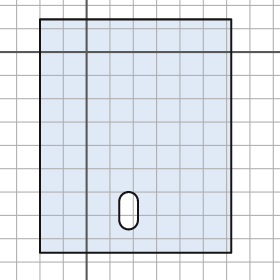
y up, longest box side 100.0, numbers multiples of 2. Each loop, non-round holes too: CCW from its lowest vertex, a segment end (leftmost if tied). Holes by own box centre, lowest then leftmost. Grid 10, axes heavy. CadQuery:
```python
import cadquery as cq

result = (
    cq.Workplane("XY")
    .moveTo(-20.0, -86.0)
    .lineTo(62.0, -86.0)
    .lineTo(62.0, 14.0)
    .lineTo(-20.0, 14.0)
    .close()
    .moveTo(14.0, -72.0)
    .threePointArc((18.0, -76.0), (22.0, -72.0))
    .lineTo(22.0, -64.0)
    .threePointArc((18.0, -60.0), (14.0, -64.0))
    .close()
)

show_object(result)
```